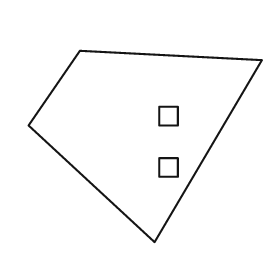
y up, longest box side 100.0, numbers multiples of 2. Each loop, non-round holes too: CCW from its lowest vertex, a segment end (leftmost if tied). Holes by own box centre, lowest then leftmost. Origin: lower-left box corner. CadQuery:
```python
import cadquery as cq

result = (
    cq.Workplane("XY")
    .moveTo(54.0, 0.0)
    .lineTo(100.0, 78.0)
    .lineTo(22.0, 82.0)
    .lineTo(0.0, 50.0)
    .close()
    .moveTo(56.0, 28.0)
    .lineTo(64.0, 28.0)
    .lineTo(64.0, 36.0)
    .lineTo(56.0, 36.0)
    .close()
    .moveTo(56.0, 50.0)
    .lineTo(64.0, 50.0)
    .lineTo(64.0, 58.0)
    .lineTo(56.0, 58.0)
    .close()
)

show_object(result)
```